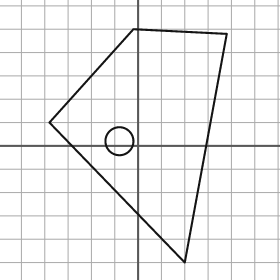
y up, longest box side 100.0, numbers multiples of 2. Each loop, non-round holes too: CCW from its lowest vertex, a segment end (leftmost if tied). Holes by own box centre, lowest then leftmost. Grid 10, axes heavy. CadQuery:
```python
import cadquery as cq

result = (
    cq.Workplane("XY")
    .moveTo(20.0, -50.0)
    .lineTo(38.0, 48.0)
    .lineTo(-2.0, 50.0)
    .lineTo(-38.0, 10.0)
    .close()
    .moveTo(-8.0, 2.0)
    .circle(6.0)
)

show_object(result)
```